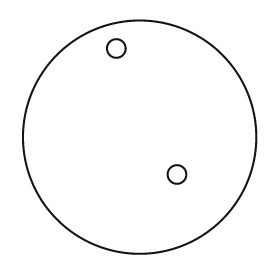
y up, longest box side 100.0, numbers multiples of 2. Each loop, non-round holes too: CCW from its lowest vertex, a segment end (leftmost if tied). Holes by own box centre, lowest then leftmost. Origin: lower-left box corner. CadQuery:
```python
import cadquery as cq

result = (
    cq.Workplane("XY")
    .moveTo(50.0, 50.0)
    .circle(50.0)
    .moveTo(66.0, 34.0)
    .circle(4.0)
    .moveTo(40.0, 88.0)
    .circle(4.0)
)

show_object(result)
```